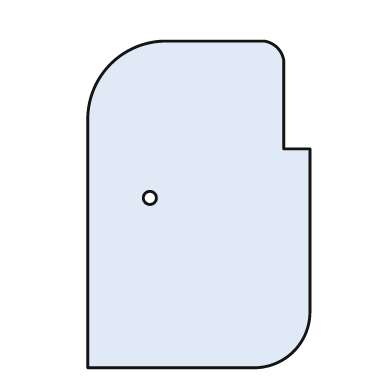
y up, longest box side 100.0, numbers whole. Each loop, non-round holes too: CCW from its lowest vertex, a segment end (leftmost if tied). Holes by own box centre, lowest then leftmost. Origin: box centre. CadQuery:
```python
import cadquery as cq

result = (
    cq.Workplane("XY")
    .moveTo(-34.0, -50.0)
    .lineTo(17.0, -50.0)
    .threePointArc((29.0, -45.0), (34.0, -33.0))
    .lineTo(34.0, 17.0)
    .lineTo(26.0, 17.0)
    .lineTo(26.0, 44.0)
    .threePointArc((24.0, 48.0), (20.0, 50.0))
    .lineTo(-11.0, 50.0)
    .threePointArc((-27.0, 43.0), (-34.0, 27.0))
    .close()
    .moveTo(-15.0, 2.0)
    .circle(2.0)
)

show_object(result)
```